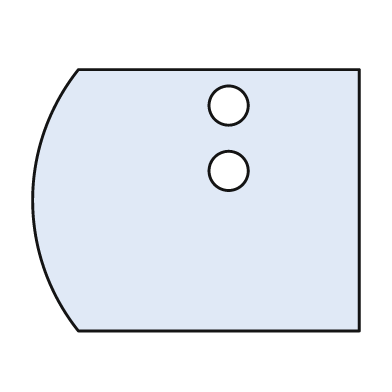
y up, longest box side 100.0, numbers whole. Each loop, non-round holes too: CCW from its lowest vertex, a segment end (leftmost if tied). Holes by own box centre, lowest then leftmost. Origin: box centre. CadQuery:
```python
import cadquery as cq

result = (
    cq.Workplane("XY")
    .moveTo(-36.0, -40.0)
    .lineTo(50.0, -40.0)
    .lineTo(50.0, 40.0)
    .lineTo(-36.0, 40.0)
    .threePointArc((-50.0, 0.0), (-36.0, -40.0))
    .close()
    .moveTo(10.0, 9.0)
    .circle(6.0)
    .moveTo(10.0, 29.0)
    .circle(6.0)
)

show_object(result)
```